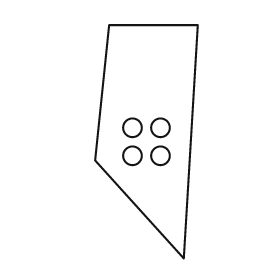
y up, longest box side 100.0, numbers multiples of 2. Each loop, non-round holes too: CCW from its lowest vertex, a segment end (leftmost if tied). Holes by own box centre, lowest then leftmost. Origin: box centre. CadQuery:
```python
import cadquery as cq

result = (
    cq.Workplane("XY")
    .moveTo(16.0, -50.0)
    .lineTo(22.0, 50.0)
    .lineTo(-16.0, 50.0)
    .lineTo(-22.0, -8.0)
    .close()
    .moveTo(-6.0, -6.0)
    .circle(4.0)
    .moveTo(6.0, -6.0)
    .circle(4.0)
    .moveTo(-6.0, 6.0)
    .circle(4.0)
    .moveTo(6.0, 6.0)
    .circle(4.0)
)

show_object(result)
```